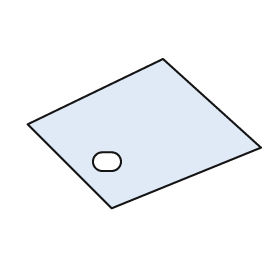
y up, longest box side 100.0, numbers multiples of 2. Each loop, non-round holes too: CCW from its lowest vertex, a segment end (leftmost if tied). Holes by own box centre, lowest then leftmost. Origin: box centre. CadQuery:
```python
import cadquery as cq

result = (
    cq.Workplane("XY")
    .moveTo(-14.0, -32.0)
    .lineTo(50.0, -6.0)
    .lineTo(8.0, 32.0)
    .lineTo(-50.0, 4.0)
    .close()
    .moveTo(-18.0, -16.0)
    .lineTo(-14.0, -16.0)
    .threePointArc((-10.0, -12.0), (-14.0, -8.0))
    .lineTo(-18.0, -8.0)
    .threePointArc((-22.0, -12.0), (-18.0, -16.0))
    .close()
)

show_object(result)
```